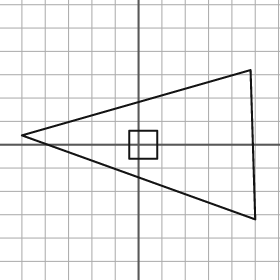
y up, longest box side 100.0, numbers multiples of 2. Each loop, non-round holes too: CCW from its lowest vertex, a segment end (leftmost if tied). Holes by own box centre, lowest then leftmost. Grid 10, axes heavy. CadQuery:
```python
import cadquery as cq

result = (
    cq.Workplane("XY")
    .moveTo(50.0, -32.0)
    .lineTo(48.0, 32.0)
    .lineTo(-50.0, 4.0)
    .close()
    .moveTo(-4.0, -6.0)
    .lineTo(8.0, -6.0)
    .lineTo(8.0, 6.0)
    .lineTo(-4.0, 6.0)
    .close()
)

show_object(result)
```